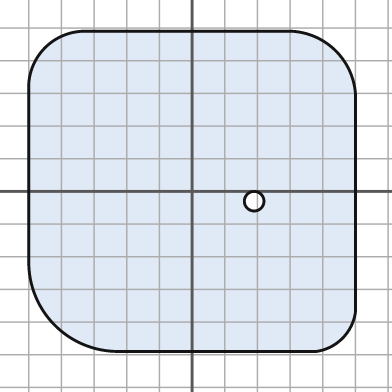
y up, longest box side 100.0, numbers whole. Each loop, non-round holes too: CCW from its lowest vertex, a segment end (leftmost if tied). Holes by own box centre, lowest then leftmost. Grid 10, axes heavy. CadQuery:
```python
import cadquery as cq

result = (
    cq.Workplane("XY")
    .moveTo(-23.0, -49.0)
    .lineTo(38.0, -49.0)
    .threePointArc((46.0, -45.0), (50.0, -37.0))
    .lineTo(50.0, 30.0)
    .threePointArc((44.0, 43.0), (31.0, 49.0))
    .lineTo(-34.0, 49.0)
    .threePointArc((-45.0, 44.0), (-50.0, 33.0))
    .lineTo(-50.0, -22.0)
    .threePointArc((-42.0, -41.0), (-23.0, -49.0))
    .close()
    .moveTo(19.0, -3.0)
    .circle(3.0)
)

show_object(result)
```